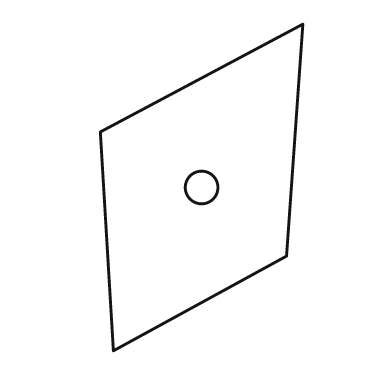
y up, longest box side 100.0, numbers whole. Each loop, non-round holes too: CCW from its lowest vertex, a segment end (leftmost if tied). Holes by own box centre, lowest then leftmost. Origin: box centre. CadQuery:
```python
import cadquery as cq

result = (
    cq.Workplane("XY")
    .moveTo(-27.0, -50.0)
    .lineTo(26.0, -21.0)
    .lineTo(31.0, 50.0)
    .lineTo(-31.0, 17.0)
    .close()
    .moveTo(0.0, 0.0)
    .circle(5.0)
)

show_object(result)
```